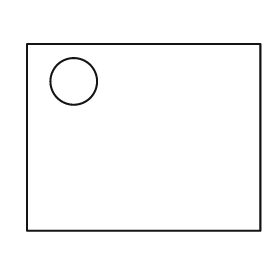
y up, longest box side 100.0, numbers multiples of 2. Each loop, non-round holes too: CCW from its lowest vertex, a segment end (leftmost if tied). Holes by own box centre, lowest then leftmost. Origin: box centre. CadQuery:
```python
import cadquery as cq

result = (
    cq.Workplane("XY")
    .moveTo(-50.0, -40.0)
    .lineTo(50.0, -40.0)
    .lineTo(50.0, 40.0)
    .lineTo(-50.0, 40.0)
    .close()
    .moveTo(-30.0, 24.0)
    .circle(10.0)
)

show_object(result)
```